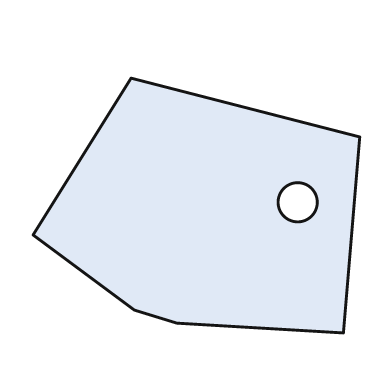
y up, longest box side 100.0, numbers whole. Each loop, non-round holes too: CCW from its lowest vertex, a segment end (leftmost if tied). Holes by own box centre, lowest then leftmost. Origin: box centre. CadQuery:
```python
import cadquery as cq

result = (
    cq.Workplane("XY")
    .moveTo(45.0, -39.0)
    .lineTo(50.0, 21.0)
    .lineTo(-20.0, 39.0)
    .lineTo(-50.0, -9.0)
    .lineTo(-19.0, -32.0)
    .lineTo(-6.0, -36.0)
    .close()
    .moveTo(31.0, 1.0)
    .circle(6.0)
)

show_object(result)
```